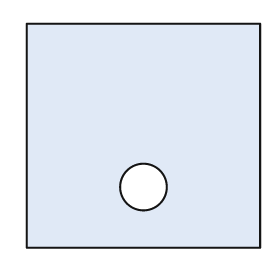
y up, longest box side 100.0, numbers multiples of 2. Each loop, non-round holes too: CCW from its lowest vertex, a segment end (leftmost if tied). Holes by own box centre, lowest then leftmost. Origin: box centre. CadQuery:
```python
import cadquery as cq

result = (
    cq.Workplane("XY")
    .moveTo(-50.0, -48.0)
    .lineTo(50.0, -48.0)
    .lineTo(50.0, 48.0)
    .lineTo(-50.0, 48.0)
    .close()
    .moveTo(0.0, -22.0)
    .circle(10.0)
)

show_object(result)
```